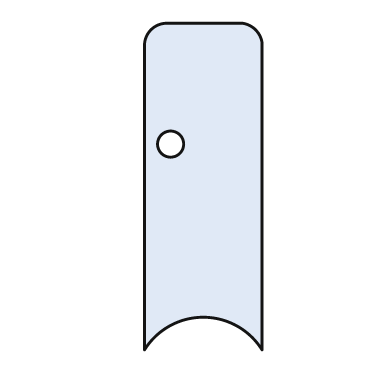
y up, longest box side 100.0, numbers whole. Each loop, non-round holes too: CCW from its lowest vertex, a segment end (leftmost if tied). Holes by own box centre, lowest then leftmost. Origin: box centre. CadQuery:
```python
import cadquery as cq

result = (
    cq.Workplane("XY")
    .moveTo(-18.0, -50.0)
    .threePointArc((0.0, -40.0), (18.0, -50.0))
    .lineTo(18.0, 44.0)
    .threePointArc((16.0, 48.0), (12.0, 50.0))
    .lineTo(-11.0, 50.0)
    .threePointArc((-16.0, 48.0), (-18.0, 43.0))
    .close()
    .moveTo(-10.0, 13.0)
    .circle(4.0)
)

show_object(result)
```